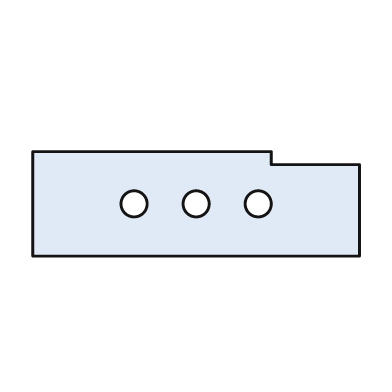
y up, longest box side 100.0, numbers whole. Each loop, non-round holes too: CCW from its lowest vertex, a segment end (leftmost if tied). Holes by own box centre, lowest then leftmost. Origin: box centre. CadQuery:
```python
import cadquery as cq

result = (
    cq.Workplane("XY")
    .moveTo(-50.0, -16.0)
    .lineTo(50.0, -16.0)
    .lineTo(50.0, 12.0)
    .lineTo(23.0, 12.0)
    .lineTo(23.0, 16.0)
    .lineTo(-50.0, 16.0)
    .close()
    .moveTo(-19.0, 0.0)
    .circle(4.0)
    .moveTo(0.0, 0.0)
    .circle(4.0)
    .moveTo(19.0, 0.0)
    .circle(4.0)
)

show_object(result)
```